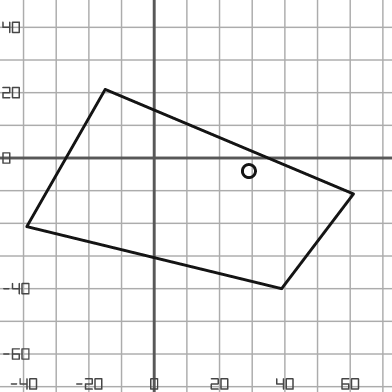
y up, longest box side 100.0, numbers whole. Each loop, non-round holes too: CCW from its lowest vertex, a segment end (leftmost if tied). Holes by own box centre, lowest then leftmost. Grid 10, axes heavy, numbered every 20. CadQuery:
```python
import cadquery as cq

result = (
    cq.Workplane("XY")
    .moveTo(39.0, -40.0)
    .lineTo(61.0, -11.0)
    .lineTo(-15.0, 21.0)
    .lineTo(-39.0, -21.0)
    .close()
    .moveTo(29.0, -4.0)
    .circle(2.0)
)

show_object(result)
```